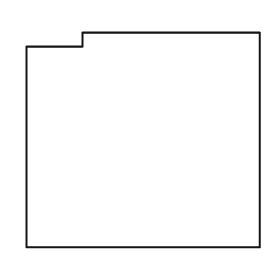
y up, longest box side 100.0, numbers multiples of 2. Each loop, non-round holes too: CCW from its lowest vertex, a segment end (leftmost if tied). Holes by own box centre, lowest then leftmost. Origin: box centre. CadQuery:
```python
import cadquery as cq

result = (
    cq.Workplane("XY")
    .moveTo(-50.0, -46.0)
    .lineTo(50.0, -46.0)
    .lineTo(50.0, 46.0)
    .lineTo(-26.0, 46.0)
    .lineTo(-26.0, 40.0)
    .lineTo(-50.0, 40.0)
    .close()
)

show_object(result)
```